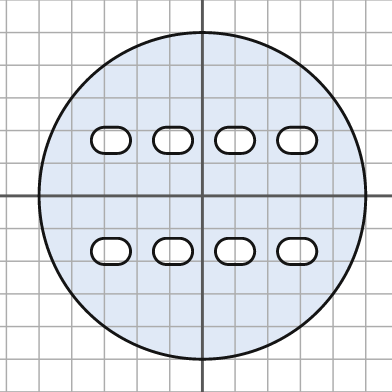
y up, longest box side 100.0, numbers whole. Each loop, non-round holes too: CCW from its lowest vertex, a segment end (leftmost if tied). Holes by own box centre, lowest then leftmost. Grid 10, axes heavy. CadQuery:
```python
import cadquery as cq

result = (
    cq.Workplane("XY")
    .moveTo(0.0, 0.0)
    .circle(50.0)
    .moveTo(-30.0, -21.0)
    .lineTo(-26.0, -21.0)
    .threePointArc((-22.0, -17.0), (-26.0, -13.0))
    .lineTo(-30.0, -13.0)
    .threePointArc((-34.0, -17.0), (-30.0, -21.0))
    .close()
    .moveTo(-11.0, -21.0)
    .lineTo(-7.0, -21.0)
    .threePointArc((-3.0, -17.0), (-7.0, -13.0))
    .lineTo(-11.0, -13.0)
    .threePointArc((-15.0, -17.0), (-11.0, -21.0))
    .close()
    .moveTo(8.0, -21.0)
    .lineTo(12.0, -21.0)
    .threePointArc((16.0, -17.0), (12.0, -13.0))
    .lineTo(8.0, -13.0)
    .threePointArc((4.0, -17.0), (8.0, -21.0))
    .close()
    .moveTo(27.0, -21.0)
    .lineTo(31.0, -21.0)
    .threePointArc((35.0, -17.0), (31.0, -13.0))
    .lineTo(27.0, -13.0)
    .threePointArc((23.0, -17.0), (27.0, -21.0))
    .close()
    .moveTo(-30.0, 13.0)
    .lineTo(-26.0, 13.0)
    .threePointArc((-22.0, 17.0), (-26.0, 21.0))
    .lineTo(-30.0, 21.0)
    .threePointArc((-34.0, 17.0), (-30.0, 13.0))
    .close()
    .moveTo(-11.0, 13.0)
    .lineTo(-7.0, 13.0)
    .threePointArc((-3.0, 17.0), (-7.0, 21.0))
    .lineTo(-11.0, 21.0)
    .threePointArc((-15.0, 17.0), (-11.0, 13.0))
    .close()
    .moveTo(8.0, 13.0)
    .lineTo(12.0, 13.0)
    .threePointArc((16.0, 17.0), (12.0, 21.0))
    .lineTo(8.0, 21.0)
    .threePointArc((4.0, 17.0), (8.0, 13.0))
    .close()
    .moveTo(27.0, 13.0)
    .lineTo(31.0, 13.0)
    .threePointArc((35.0, 17.0), (31.0, 21.0))
    .lineTo(27.0, 21.0)
    .threePointArc((23.0, 17.0), (27.0, 13.0))
    .close()
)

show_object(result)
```